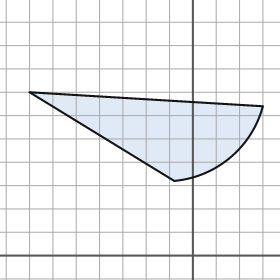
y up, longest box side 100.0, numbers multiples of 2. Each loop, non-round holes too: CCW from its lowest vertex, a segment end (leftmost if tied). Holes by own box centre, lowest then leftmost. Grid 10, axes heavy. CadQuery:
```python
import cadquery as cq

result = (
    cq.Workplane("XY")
    .moveTo(-8.0, 32.0)
    .threePointArc((16.0, 42.0), (30.0, 64.0))
    .lineTo(-70.0, 70.0)
    .close()
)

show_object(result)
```